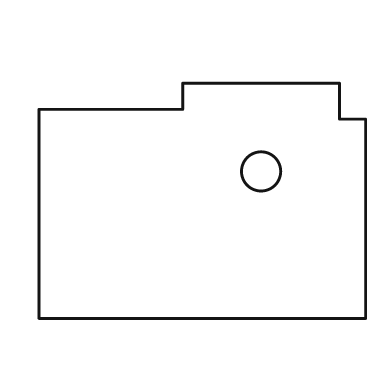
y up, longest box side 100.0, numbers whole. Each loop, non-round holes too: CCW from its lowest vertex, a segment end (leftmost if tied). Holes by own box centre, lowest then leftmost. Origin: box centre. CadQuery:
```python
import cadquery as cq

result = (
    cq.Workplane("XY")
    .moveTo(-50.0, -36.0)
    .lineTo(50.0, -36.0)
    .lineTo(50.0, 25.0)
    .lineTo(42.0, 25.0)
    .lineTo(42.0, 36.0)
    .lineTo(-6.0, 36.0)
    .lineTo(-6.0, 28.0)
    .lineTo(-50.0, 28.0)
    .close()
    .moveTo(18.0, 9.0)
    .circle(6.0)
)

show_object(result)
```